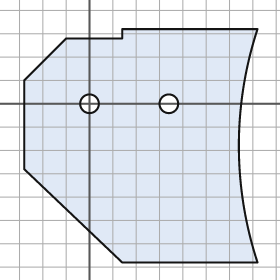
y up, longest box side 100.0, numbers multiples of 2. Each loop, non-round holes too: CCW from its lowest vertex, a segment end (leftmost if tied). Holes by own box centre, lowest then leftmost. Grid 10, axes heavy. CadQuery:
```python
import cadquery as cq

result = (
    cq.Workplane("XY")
    .moveTo(14.0, -68.0)
    .lineTo(72.0, -68.0)
    .threePointArc((64.0, -18.0), (72.0, 32.0))
    .lineTo(14.0, 32.0)
    .lineTo(14.0, 28.0)
    .lineTo(-10.0, 28.0)
    .lineTo(-28.0, 10.0)
    .lineTo(-28.0, -28.0)
    .close()
    .moveTo(0.0, 0.0)
    .circle(4.0)
    .moveTo(34.0, 0.0)
    .circle(4.0)
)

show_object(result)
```